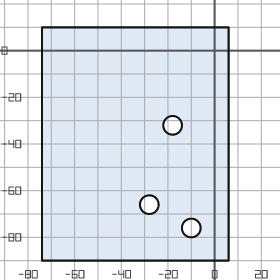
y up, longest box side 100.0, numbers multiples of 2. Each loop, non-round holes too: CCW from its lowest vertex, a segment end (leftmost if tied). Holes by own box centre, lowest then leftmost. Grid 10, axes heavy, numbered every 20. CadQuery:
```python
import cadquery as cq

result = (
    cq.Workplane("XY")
    .moveTo(-74.0, -90.0)
    .lineTo(6.0, -90.0)
    .lineTo(6.0, 10.0)
    .lineTo(-74.0, 10.0)
    .close()
    .moveTo(-10.0, -76.0)
    .circle(4.0)
    .moveTo(-28.0, -66.0)
    .circle(4.0)
    .moveTo(-18.0, -32.0)
    .circle(4.0)
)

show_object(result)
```